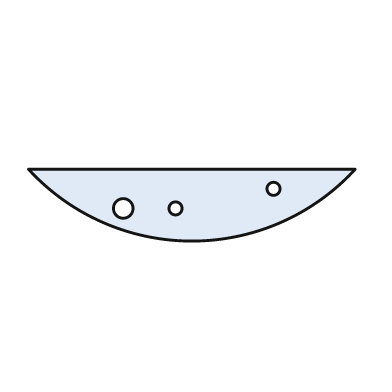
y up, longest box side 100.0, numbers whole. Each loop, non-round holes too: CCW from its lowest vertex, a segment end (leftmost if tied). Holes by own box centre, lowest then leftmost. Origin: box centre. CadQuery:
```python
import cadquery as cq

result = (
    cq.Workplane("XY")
    .moveTo(-50.0, 11.0)
    .threePointArc((0.0, -11.0), (50.0, 11.0))
    .close()
    .moveTo(-21.0, -1.0)
    .circle(3.0)
    .moveTo(-5.0, -1.0)
    .circle(2.0)
    .moveTo(25.0, 5.0)
    .circle(2.0)
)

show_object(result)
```